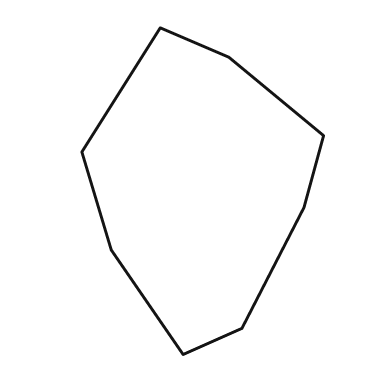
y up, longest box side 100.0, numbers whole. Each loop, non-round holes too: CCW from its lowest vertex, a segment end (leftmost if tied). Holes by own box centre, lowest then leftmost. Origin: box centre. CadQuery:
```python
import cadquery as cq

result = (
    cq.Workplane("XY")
    .moveTo(-6.0, -50.0)
    .lineTo(12.0, -42.0)
    .lineTo(31.0, -5.0)
    .lineTo(37.0, 17.0)
    .lineTo(8.0, 41.0)
    .lineTo(-13.0, 50.0)
    .lineTo(-37.0, 12.0)
    .lineTo(-28.0, -18.0)
    .close()
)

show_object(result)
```